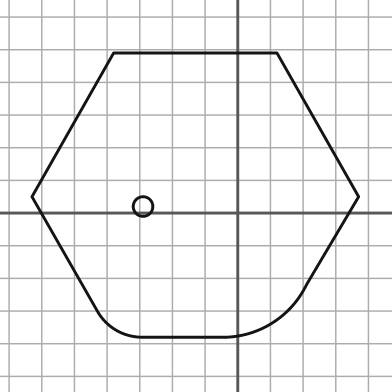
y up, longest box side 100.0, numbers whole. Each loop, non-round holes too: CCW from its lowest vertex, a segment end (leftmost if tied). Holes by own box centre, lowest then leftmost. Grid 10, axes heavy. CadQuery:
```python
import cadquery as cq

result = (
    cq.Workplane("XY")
    .moveTo(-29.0, -38.0)
    .lineTo(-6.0, -38.0)
    .threePointArc((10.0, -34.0), (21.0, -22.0))
    .lineTo(37.0, 5.0)
    .lineTo(12.0, 49.0)
    .lineTo(-38.0, 49.0)
    .lineTo(-63.0, 5.0)
    .lineTo(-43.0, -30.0)
    .threePointArc((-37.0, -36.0), (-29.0, -38.0))
    .close()
    .moveTo(-29.0, 2.0)
    .circle(3.0)
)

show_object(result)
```